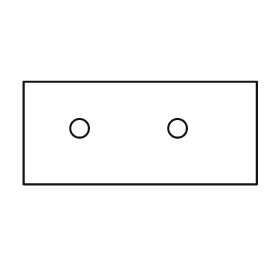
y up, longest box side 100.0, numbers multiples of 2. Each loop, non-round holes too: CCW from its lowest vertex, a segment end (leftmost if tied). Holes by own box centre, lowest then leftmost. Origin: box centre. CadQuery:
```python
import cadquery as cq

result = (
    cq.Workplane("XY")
    .moveTo(-50.0, -22.0)
    .lineTo(50.0, -22.0)
    .lineTo(50.0, 22.0)
    .lineTo(-50.0, 22.0)
    .close()
    .moveTo(-26.0, 2.0)
    .circle(4.0)
    .moveTo(16.0, 2.0)
    .circle(4.0)
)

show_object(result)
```